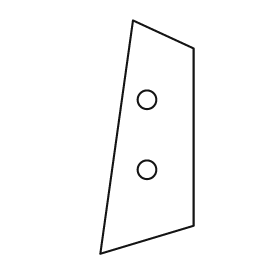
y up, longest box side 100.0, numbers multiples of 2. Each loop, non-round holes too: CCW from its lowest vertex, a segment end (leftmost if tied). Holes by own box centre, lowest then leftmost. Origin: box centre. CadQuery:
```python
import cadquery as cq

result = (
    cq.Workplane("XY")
    .moveTo(-20.0, -50.0)
    .lineTo(20.0, -38.0)
    .lineTo(20.0, 38.0)
    .lineTo(-6.0, 50.0)
    .close()
    .moveTo(0.0, -14.0)
    .circle(4.0)
    .moveTo(0.0, 16.0)
    .circle(4.0)
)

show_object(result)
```